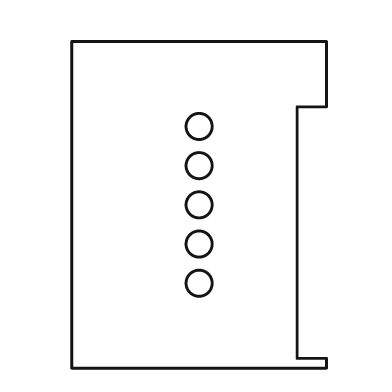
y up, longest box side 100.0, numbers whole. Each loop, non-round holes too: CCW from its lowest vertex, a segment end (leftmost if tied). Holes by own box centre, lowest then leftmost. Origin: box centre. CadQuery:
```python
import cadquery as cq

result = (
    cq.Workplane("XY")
    .moveTo(-39.0, -50.0)
    .lineTo(39.0, -50.0)
    .lineTo(39.0, -47.0)
    .lineTo(30.0, -47.0)
    .lineTo(30.0, 30.0)
    .lineTo(39.0, 30.0)
    .lineTo(39.0, 50.0)
    .lineTo(-39.0, 50.0)
    .close()
    .moveTo(0.0, -24.0)
    .circle(4.0)
    .moveTo(0.0, -12.0)
    .circle(4.0)
    .moveTo(0.0, 0.0)
    .circle(4.0)
    .moveTo(0.0, 12.0)
    .circle(4.0)
    .moveTo(0.0, 24.0)
    .circle(4.0)
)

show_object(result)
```